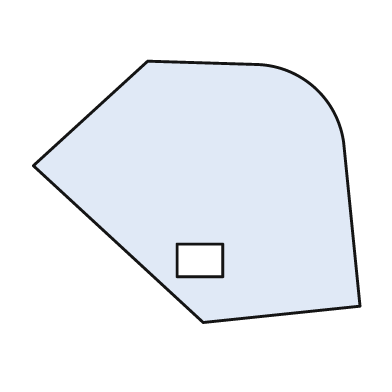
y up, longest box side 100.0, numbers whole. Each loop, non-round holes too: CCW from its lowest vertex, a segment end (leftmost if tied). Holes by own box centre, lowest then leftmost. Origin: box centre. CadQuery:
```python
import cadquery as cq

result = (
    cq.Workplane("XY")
    .moveTo(2.0, -40.0)
    .lineTo(50.0, -35.0)
    .lineTo(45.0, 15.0)
    .threePointArc((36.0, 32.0), (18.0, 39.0))
    .lineTo(-15.0, 40.0)
    .lineTo(-50.0, 8.0)
    .close()
    .moveTo(-6.0, -26.0)
    .lineTo(8.0, -26.0)
    .lineTo(8.0, -16.0)
    .lineTo(-6.0, -16.0)
    .close()
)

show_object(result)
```